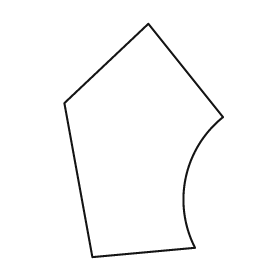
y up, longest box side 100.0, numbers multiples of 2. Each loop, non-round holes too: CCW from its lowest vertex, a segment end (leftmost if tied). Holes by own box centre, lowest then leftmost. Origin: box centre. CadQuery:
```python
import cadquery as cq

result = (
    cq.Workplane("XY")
    .moveTo(-22.0, -50.0)
    .lineTo(22.0, -46.0)
    .threePointArc((18.0, -16.0), (34.0, 10.0))
    .lineTo(2.0, 50.0)
    .lineTo(-34.0, 16.0)
    .close()
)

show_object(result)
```